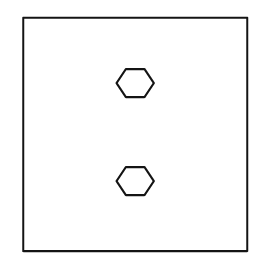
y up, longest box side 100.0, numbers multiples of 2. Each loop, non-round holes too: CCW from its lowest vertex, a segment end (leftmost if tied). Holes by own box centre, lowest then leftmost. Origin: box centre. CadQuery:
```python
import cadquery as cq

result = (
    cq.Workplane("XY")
    .moveTo(-48.0, -50.0)
    .lineTo(48.0, -50.0)
    .lineTo(48.0, 50.0)
    .lineTo(-48.0, 50.0)
    .close()
    .moveTo(-4.0, -26.0)
    .lineTo(4.0, -26.0)
    .lineTo(8.0, -20.0)
    .lineTo(4.0, -14.0)
    .lineTo(-4.0, -14.0)
    .lineTo(-8.0, -20.0)
    .close()
    .moveTo(-4.0, 16.0)
    .lineTo(4.0, 16.0)
    .lineTo(8.0, 22.0)
    .lineTo(4.0, 28.0)
    .lineTo(-4.0, 28.0)
    .lineTo(-8.0, 22.0)
    .close()
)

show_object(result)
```